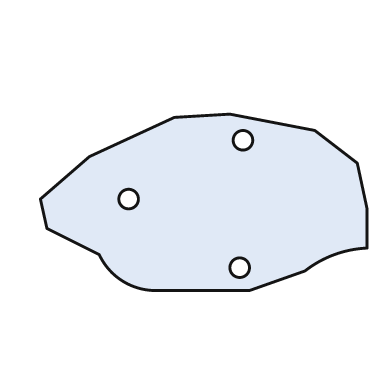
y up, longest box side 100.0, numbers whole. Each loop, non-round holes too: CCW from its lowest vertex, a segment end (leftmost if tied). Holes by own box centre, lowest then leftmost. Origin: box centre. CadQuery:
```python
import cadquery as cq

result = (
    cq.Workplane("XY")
    .moveTo(-15.0, -27.0)
    .lineTo(14.0, -27.0)
    .lineTo(31.0, -21.0)
    .threePointArc((40.0, -16.0), (50.0, -14.0))
    .lineTo(50.0, -2.0)
    .lineTo(47.0, 12.0)
    .lineTo(34.0, 22.0)
    .lineTo(8.0, 27.0)
    .lineTo(-9.0, 26.0)
    .lineTo(-35.0, 14.0)
    .lineTo(-50.0, 1.0)
    .lineTo(-48.0, -8.0)
    .lineTo(-32.0, -16.0)
    .threePointArc((-25.0, -24.0), (-15.0, -27.0))
    .close()
    .moveTo(11.0, -20.0)
    .circle(3.0)
    .moveTo(-23.0, 1.0)
    .circle(3.0)
    .moveTo(12.0, 19.0)
    .circle(3.0)
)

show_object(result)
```